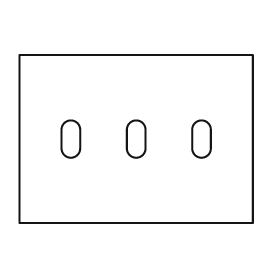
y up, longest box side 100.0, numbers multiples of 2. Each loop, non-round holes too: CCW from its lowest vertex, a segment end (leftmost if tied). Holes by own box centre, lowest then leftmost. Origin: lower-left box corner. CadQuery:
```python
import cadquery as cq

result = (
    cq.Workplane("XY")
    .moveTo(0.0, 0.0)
    .lineTo(100.0, 0.0)
    .lineTo(100.0, 72.0)
    .lineTo(0.0, 72.0)
    .close()
    .moveTo(18.0, 32.0)
    .threePointArc((22.0, 28.0), (26.0, 32.0))
    .lineTo(26.0, 40.0)
    .threePointArc((22.0, 44.0), (18.0, 40.0))
    .close()
    .moveTo(46.0, 32.0)
    .threePointArc((50.0, 28.0), (54.0, 32.0))
    .lineTo(54.0, 40.0)
    .threePointArc((50.0, 44.0), (46.0, 40.0))
    .close()
    .moveTo(74.0, 32.0)
    .threePointArc((78.0, 28.0), (82.0, 32.0))
    .lineTo(82.0, 40.0)
    .threePointArc((78.0, 44.0), (74.0, 40.0))
    .close()
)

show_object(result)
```